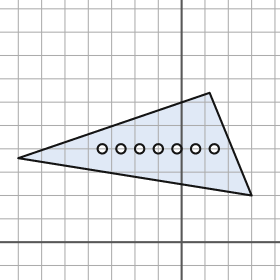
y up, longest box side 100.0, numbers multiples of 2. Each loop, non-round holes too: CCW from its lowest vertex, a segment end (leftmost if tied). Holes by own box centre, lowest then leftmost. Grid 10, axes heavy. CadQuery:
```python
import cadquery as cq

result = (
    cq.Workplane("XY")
    .moveTo(30.0, 20.0)
    .lineTo(12.0, 64.0)
    .lineTo(-70.0, 36.0)
    .close()
    .moveTo(-34.0, 40.0)
    .circle(2.0)
    .moveTo(-26.0, 40.0)
    .circle(2.0)
    .moveTo(-18.0, 40.0)
    .circle(2.0)
    .moveTo(-10.0, 40.0)
    .circle(2.0)
    .moveTo(-2.0, 40.0)
    .circle(2.0)
    .moveTo(6.0, 40.0)
    .circle(2.0)
    .moveTo(14.0, 40.0)
    .circle(2.0)
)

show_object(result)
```